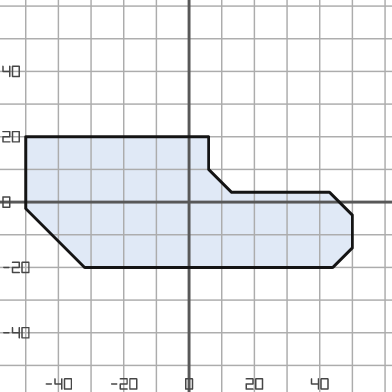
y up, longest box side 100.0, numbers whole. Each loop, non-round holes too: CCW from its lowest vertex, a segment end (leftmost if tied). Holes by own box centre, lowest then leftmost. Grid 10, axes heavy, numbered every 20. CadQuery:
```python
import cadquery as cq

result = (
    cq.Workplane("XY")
    .moveTo(-32.0, -20.0)
    .lineTo(44.0, -20.0)
    .lineTo(50.0, -14.0)
    .lineTo(50.0, -4.0)
    .lineTo(43.0, 3.0)
    .lineTo(13.0, 3.0)
    .lineTo(6.0, 10.0)
    .lineTo(6.0, 20.0)
    .lineTo(-50.0, 20.0)
    .lineTo(-50.0, -2.0)
    .close()
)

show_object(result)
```